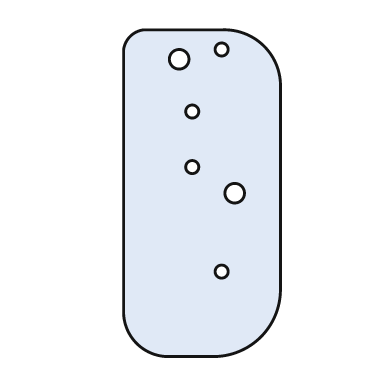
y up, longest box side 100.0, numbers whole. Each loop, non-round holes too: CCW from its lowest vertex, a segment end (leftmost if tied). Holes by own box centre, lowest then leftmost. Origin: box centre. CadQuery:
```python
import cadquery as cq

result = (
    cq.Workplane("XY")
    .moveTo(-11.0, -50.0)
    .lineTo(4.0, -50.0)
    .threePointArc((18.0, -44.0), (24.0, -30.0))
    .lineTo(24.0, 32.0)
    .threePointArc((19.0, 45.0), (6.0, 50.0))
    .lineTo(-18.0, 50.0)
    .threePointArc((-22.0, 48.0), (-24.0, 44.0))
    .lineTo(-24.0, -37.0)
    .threePointArc((-20.0, -46.0), (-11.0, -50.0))
    .close()
    .moveTo(6.0, -24.0)
    .circle(2.0)
    .moveTo(10.0, 0.0)
    .circle(3.0)
    .moveTo(-3.0, 8.0)
    .circle(2.0)
    .moveTo(-3.0, 25.0)
    .circle(2.0)
    .moveTo(-7.0, 41.0)
    .circle(3.0)
    .moveTo(6.0, 44.0)
    .circle(2.0)
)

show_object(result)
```